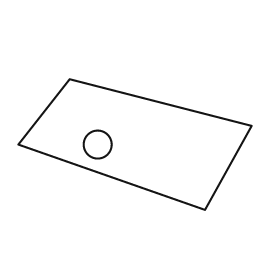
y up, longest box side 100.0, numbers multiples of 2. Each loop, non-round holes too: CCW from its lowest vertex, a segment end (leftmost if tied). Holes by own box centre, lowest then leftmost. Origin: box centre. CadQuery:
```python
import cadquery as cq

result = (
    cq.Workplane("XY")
    .moveTo(30.0, -28.0)
    .lineTo(50.0, 8.0)
    .lineTo(-28.0, 28.0)
    .lineTo(-50.0, 0.0)
    .close()
    .moveTo(-16.0, 0.0)
    .circle(6.0)
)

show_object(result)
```